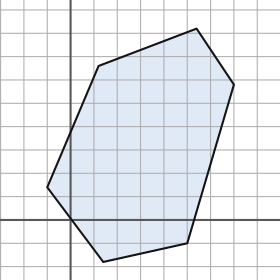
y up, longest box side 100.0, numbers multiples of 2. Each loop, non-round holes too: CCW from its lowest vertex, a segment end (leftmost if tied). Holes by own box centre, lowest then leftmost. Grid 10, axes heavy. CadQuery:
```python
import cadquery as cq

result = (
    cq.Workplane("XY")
    .moveTo(14.0, -18.0)
    .lineTo(50.0, -10.0)
    .lineTo(70.0, 58.0)
    .lineTo(54.0, 82.0)
    .lineTo(12.0, 66.0)
    .lineTo(-10.0, 14.0)
    .close()
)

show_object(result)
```